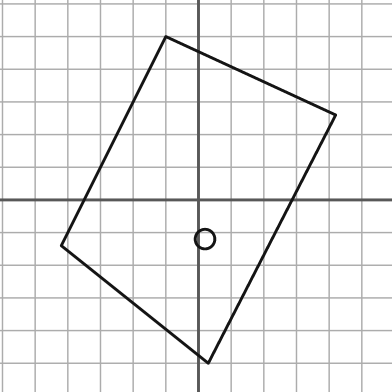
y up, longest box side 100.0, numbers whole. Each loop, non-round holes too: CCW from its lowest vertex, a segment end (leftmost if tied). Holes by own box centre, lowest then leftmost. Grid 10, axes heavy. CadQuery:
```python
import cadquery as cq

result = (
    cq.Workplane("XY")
    .moveTo(3.0, -50.0)
    .lineTo(42.0, 26.0)
    .lineTo(-10.0, 50.0)
    .lineTo(-42.0, -14.0)
    .close()
    .moveTo(2.0, -12.0)
    .circle(3.0)
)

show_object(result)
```